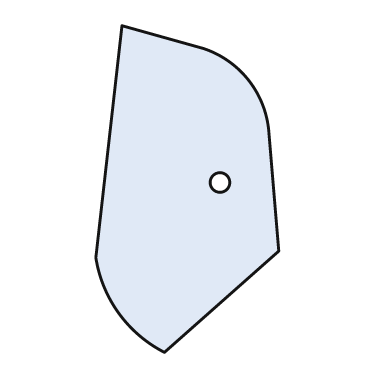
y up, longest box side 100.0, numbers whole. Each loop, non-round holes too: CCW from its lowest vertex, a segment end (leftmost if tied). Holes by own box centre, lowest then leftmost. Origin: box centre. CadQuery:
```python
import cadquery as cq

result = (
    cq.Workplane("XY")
    .moveTo(-7.0, -50.0)
    .lineTo(28.0, -19.0)
    .lineTo(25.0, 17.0)
    .threePointArc((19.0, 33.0), (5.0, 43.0))
    .lineTo(-20.0, 50.0)
    .lineTo(-28.0, -21.0)
    .threePointArc((-21.0, -38.0), (-7.0, -50.0))
    .close()
    .moveTo(10.0, 2.0)
    .circle(3.0)
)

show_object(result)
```